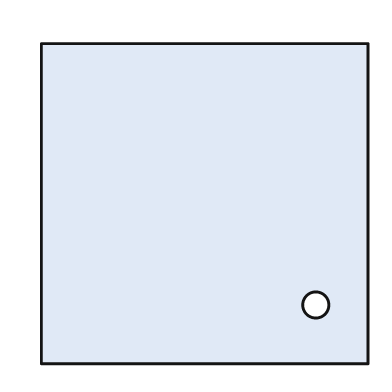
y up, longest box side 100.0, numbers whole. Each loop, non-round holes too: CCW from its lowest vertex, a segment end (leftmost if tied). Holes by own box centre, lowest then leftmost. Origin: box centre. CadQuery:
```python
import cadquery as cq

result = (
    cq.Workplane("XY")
    .moveTo(-50.0, -49.0)
    .lineTo(50.0, -49.0)
    .lineTo(50.0, 49.0)
    .lineTo(-50.0, 49.0)
    .close()
    .moveTo(34.0, -31.0)
    .circle(4.0)
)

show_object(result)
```